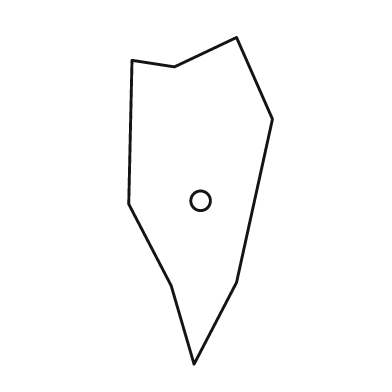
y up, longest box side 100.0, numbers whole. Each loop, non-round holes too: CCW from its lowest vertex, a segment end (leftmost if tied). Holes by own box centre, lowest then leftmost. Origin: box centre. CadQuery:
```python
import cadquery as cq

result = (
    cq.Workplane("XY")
    .moveTo(-2.0, -50.0)
    .lineTo(11.0, -25.0)
    .lineTo(22.0, 25.0)
    .lineTo(11.0, 50.0)
    .lineTo(-8.0, 41.0)
    .lineTo(-21.0, 43.0)
    .lineTo(-22.0, -1.0)
    .lineTo(-9.0, -26.0)
    .close()
    .moveTo(0.0, 0.0)
    .circle(3.0)
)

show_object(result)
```